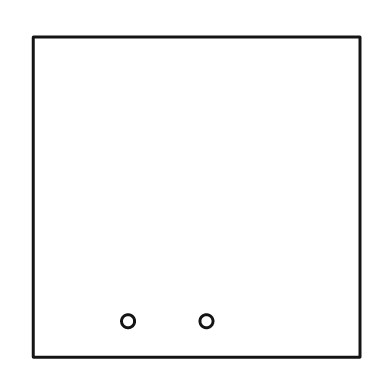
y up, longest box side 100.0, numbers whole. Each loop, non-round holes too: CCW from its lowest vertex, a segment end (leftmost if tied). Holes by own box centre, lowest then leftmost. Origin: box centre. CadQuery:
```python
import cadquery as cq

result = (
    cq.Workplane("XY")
    .moveTo(-50.0, -49.0)
    .lineTo(50.0, -49.0)
    .lineTo(50.0, 49.0)
    .lineTo(-50.0, 49.0)
    .close()
    .moveTo(-21.0, -38.0)
    .circle(2.0)
    .moveTo(3.0, -38.0)
    .circle(2.0)
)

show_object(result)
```